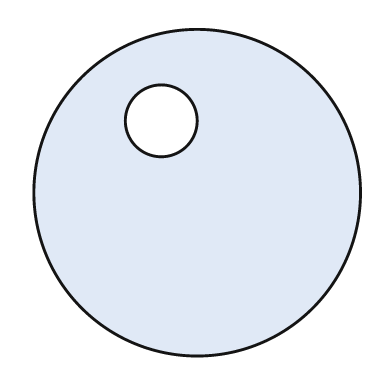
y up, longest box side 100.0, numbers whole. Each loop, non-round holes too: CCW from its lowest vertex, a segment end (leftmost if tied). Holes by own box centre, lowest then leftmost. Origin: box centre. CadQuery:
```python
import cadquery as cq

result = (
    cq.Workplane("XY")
    .moveTo(0.0, 0.0)
    .circle(50.0)
    .moveTo(-11.0, 22.0)
    .circle(11.0)
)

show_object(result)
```